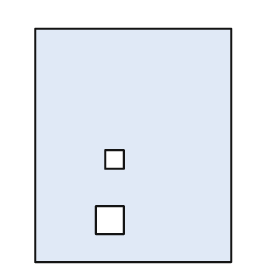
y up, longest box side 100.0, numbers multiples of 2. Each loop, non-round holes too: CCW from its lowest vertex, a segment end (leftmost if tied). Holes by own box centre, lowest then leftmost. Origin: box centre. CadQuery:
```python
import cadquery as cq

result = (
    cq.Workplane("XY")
    .moveTo(-42.0, -50.0)
    .lineTo(42.0, -50.0)
    .lineTo(42.0, 50.0)
    .lineTo(-42.0, 50.0)
    .close()
    .moveTo(-16.0, -38.0)
    .lineTo(-4.0, -38.0)
    .lineTo(-4.0, -26.0)
    .lineTo(-16.0, -26.0)
    .close()
    .moveTo(-12.0, -10.0)
    .lineTo(-4.0, -10.0)
    .lineTo(-4.0, -2.0)
    .lineTo(-12.0, -2.0)
    .close()
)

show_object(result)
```